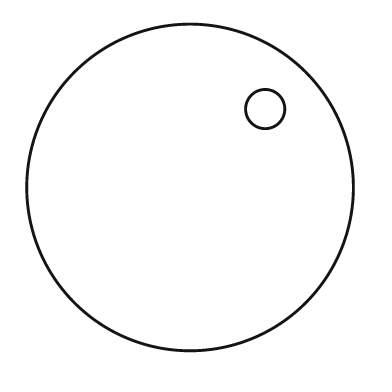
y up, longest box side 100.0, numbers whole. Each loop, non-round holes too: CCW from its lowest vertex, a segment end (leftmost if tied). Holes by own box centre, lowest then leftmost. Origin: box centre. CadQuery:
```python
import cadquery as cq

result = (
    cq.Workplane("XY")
    .moveTo(0.0, 0.0)
    .circle(50.0)
    .moveTo(23.0, 24.0)
    .circle(6.0)
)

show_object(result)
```